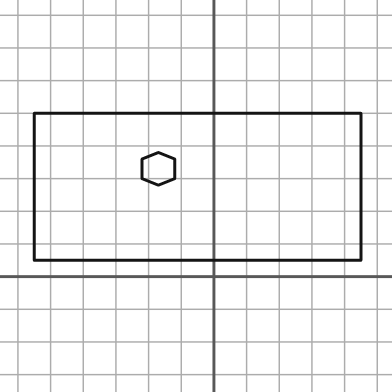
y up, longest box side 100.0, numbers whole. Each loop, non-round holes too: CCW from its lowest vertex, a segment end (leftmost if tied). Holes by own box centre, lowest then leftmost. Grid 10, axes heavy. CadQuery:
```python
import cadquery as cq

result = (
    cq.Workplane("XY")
    .moveTo(-55.0, 5.0)
    .lineTo(45.0, 5.0)
    .lineTo(45.0, 50.0)
    .lineTo(-55.0, 50.0)
    .close()
    .moveTo(-17.0, 28.0)
    .lineTo(-12.0, 30.0)
    .lineTo(-12.0, 36.0)
    .lineTo(-17.0, 38.0)
    .lineTo(-22.0, 36.0)
    .lineTo(-22.0, 30.0)
    .close()
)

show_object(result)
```